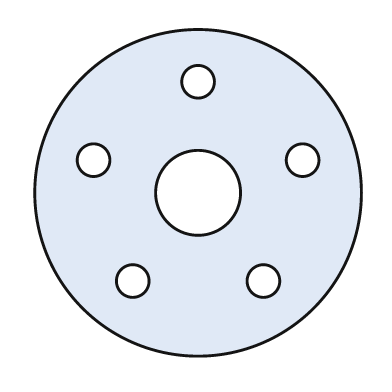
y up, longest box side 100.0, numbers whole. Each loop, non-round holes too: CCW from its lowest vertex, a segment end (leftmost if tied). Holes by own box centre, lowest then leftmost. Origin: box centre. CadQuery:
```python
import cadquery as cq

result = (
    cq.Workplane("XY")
    .moveTo(0.0, 0.0)
    .circle(50.0)
    .moveTo(-20.0, -27.0)
    .circle(5.0)
    .moveTo(20.0, -27.0)
    .circle(5.0)
    .moveTo(0.0, 0.0)
    .circle(13.0)
    .moveTo(-32.0, 10.0)
    .circle(5.0)
    .moveTo(32.0, 10.0)
    .circle(5.0)
    .moveTo(0.0, 34.0)
    .circle(5.0)
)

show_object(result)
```